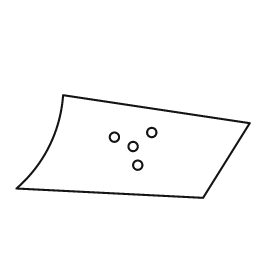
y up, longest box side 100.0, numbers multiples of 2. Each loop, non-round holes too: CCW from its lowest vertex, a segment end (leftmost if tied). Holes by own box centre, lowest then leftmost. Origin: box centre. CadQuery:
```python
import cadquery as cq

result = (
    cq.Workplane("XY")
    .moveTo(30.0, -22.0)
    .lineTo(50.0, 10.0)
    .lineTo(-30.0, 22.0)
    .threePointArc((-36.0, 0.0), (-50.0, -18.0))
    .close()
    .moveTo(2.0, -8.0)
    .circle(2.0)
    .moveTo(0.0, 0.0)
    .circle(2.0)
    .moveTo(-8.0, 4.0)
    .circle(2.0)
    .moveTo(8.0, 6.0)
    .circle(2.0)
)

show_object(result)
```